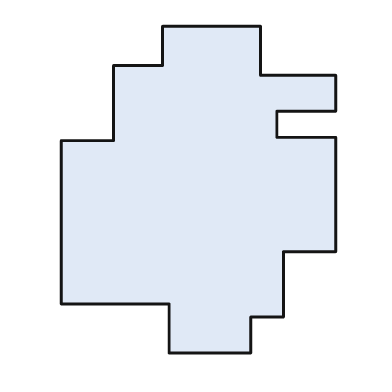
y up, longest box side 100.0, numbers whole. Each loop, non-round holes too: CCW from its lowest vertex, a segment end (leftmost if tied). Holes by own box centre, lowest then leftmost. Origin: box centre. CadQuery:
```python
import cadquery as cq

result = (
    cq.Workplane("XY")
    .moveTo(-9.0, -50.0)
    .lineTo(16.0, -50.0)
    .lineTo(16.0, -39.0)
    .lineTo(26.0, -39.0)
    .lineTo(26.0, -19.0)
    .lineTo(42.0, -19.0)
    .lineTo(42.0, 16.0)
    .lineTo(24.0, 16.0)
    .lineTo(24.0, 24.0)
    .lineTo(42.0, 24.0)
    .lineTo(42.0, 35.0)
    .lineTo(19.0, 35.0)
    .lineTo(19.0, 50.0)
    .lineTo(-11.0, 50.0)
    .lineTo(-11.0, 38.0)
    .lineTo(-26.0, 38.0)
    .lineTo(-26.0, 15.0)
    .lineTo(-42.0, 15.0)
    .lineTo(-42.0, -35.0)
    .lineTo(-9.0, -35.0)
    .close()
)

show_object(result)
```